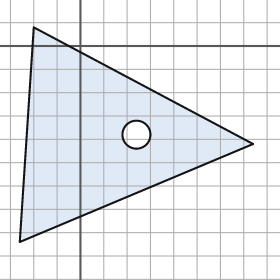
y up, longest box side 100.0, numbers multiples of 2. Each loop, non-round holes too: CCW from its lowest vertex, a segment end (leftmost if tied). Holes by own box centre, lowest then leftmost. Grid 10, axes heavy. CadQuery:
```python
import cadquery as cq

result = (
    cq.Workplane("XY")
    .moveTo(-26.0, -84.0)
    .lineTo(74.0, -42.0)
    .lineTo(-20.0, 8.0)
    .close()
    .moveTo(24.0, -38.0)
    .circle(6.0)
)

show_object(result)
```